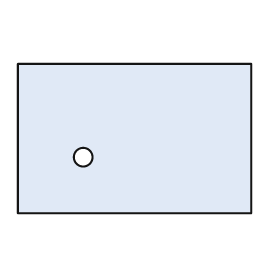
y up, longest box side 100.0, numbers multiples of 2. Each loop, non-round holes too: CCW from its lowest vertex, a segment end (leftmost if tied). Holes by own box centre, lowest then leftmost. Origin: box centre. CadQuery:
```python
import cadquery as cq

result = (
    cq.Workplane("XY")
    .moveTo(-50.0, -32.0)
    .lineTo(50.0, -32.0)
    .lineTo(50.0, 32.0)
    .lineTo(-50.0, 32.0)
    .close()
    .moveTo(-22.0, -8.0)
    .circle(4.0)
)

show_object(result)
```